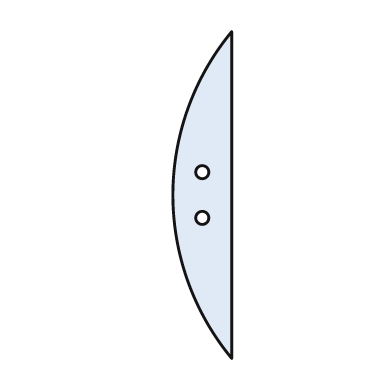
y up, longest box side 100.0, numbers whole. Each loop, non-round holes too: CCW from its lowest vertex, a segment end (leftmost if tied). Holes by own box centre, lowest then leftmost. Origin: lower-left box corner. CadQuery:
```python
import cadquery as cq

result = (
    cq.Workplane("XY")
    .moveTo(18.0, 0.0)
    .lineTo(18.0, 100.0)
    .threePointArc((0.0, 50.0), (18.0, 0.0))
    .close()
    .moveTo(9.0, 43.0)
    .circle(2.0)
    .moveTo(9.0, 57.0)
    .circle(2.0)
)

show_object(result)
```